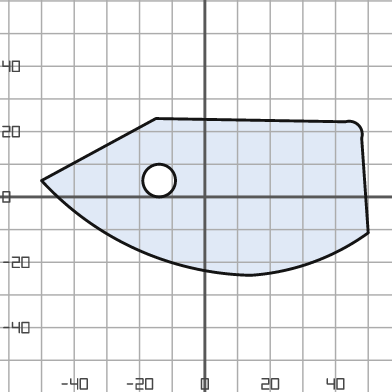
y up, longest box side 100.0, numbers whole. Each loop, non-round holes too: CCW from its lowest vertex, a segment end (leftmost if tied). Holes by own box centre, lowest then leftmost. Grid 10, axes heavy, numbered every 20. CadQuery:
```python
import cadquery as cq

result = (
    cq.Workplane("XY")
    .moveTo(14.0, -24.0)
    .threePointArc((33.0, -20.0), (50.0, -11.0))
    .lineTo(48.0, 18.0)
    .threePointArc((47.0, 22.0), (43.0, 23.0))
    .lineTo(-15.0, 24.0)
    .lineTo(-50.0, 5.0)
    .threePointArc((-21.0, -16.0), (14.0, -24.0))
    .close()
    .moveTo(-14.0, 5.0)
    .circle(5.0)
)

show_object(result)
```